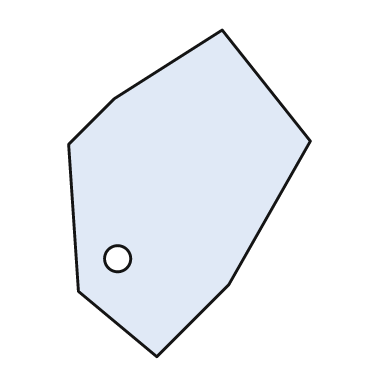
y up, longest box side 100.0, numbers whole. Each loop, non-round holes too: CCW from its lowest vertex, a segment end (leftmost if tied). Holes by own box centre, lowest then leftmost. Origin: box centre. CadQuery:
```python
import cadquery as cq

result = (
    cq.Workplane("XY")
    .moveTo(-10.0, -50.0)
    .lineTo(12.0, -28.0)
    .lineTo(37.0, 16.0)
    .lineTo(10.0, 50.0)
    .lineTo(-23.0, 29.0)
    .lineTo(-37.0, 15.0)
    .lineTo(-34.0, -30.0)
    .close()
    .moveTo(-22.0, -20.0)
    .circle(4.0)
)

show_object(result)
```